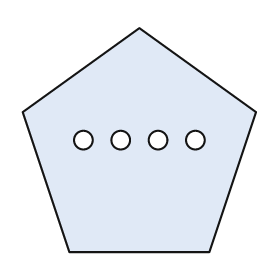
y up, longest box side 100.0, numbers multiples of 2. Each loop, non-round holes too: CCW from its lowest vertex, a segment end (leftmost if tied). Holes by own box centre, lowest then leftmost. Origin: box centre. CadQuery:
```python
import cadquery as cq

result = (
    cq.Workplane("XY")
    .moveTo(-30.0, -48.0)
    .lineTo(30.0, -48.0)
    .lineTo(50.0, 12.0)
    .lineTo(0.0, 48.0)
    .lineTo(-50.0, 12.0)
    .close()
    .moveTo(-24.0, 0.0)
    .circle(4.0)
    .moveTo(-8.0, 0.0)
    .circle(4.0)
    .moveTo(8.0, 0.0)
    .circle(4.0)
    .moveTo(24.0, 0.0)
    .circle(4.0)
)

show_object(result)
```